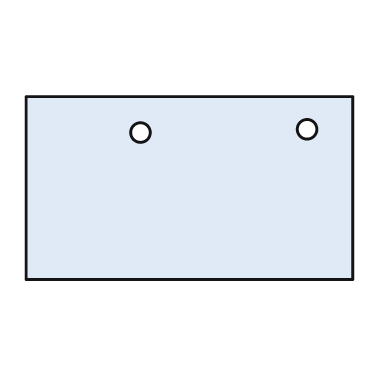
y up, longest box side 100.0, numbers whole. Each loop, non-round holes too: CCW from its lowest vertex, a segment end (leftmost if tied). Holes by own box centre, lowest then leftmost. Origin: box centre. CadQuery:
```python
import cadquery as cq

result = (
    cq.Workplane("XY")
    .moveTo(-50.0, -28.0)
    .lineTo(50.0, -28.0)
    .lineTo(50.0, 28.0)
    .lineTo(-50.0, 28.0)
    .close()
    .moveTo(-15.0, 17.0)
    .circle(3.0)
    .moveTo(36.0, 18.0)
    .circle(3.0)
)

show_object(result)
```